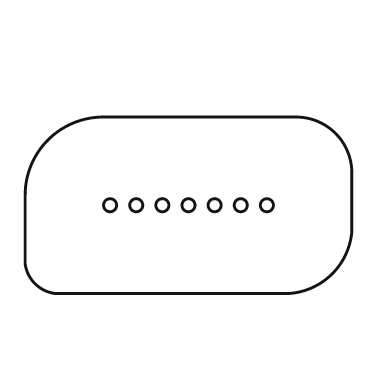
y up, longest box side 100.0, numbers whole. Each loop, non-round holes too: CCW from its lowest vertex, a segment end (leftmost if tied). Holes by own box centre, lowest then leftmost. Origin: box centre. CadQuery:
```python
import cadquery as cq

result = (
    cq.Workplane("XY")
    .moveTo(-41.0, -27.0)
    .lineTo(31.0, -27.0)
    .threePointArc((44.0, -21.0), (50.0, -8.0))
    .lineTo(50.0, 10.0)
    .threePointArc((45.0, 22.0), (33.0, 27.0))
    .lineTo(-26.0, 27.0)
    .threePointArc((-43.0, 20.0), (-50.0, 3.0))
    .lineTo(-50.0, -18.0)
    .threePointArc((-47.0, -24.0), (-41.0, -27.0))
    .close()
    .moveTo(-24.0, 0.0)
    .circle(2.0)
    .moveTo(-16.0, 0.0)
    .circle(2.0)
    .moveTo(-8.0, 0.0)
    .circle(2.0)
    .moveTo(0.0, 0.0)
    .circle(2.0)
    .moveTo(8.0, 0.0)
    .circle(2.0)
    .moveTo(16.0, 0.0)
    .circle(2.0)
    .moveTo(24.0, 0.0)
    .circle(2.0)
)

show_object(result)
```